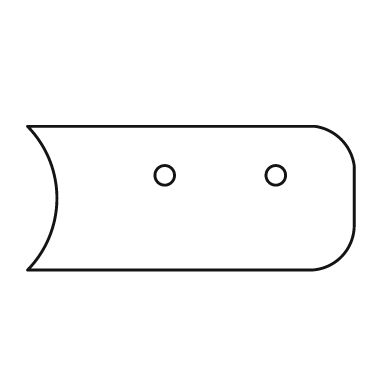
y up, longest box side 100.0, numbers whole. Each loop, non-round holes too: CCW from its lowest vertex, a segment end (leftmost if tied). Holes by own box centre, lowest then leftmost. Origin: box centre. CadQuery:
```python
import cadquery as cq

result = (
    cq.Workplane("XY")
    .moveTo(-50.0, -22.0)
    .lineTo(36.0, -22.0)
    .threePointArc((46.0, -18.0), (50.0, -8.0))
    .lineTo(50.0, 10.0)
    .threePointArc((46.0, 18.0), (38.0, 22.0))
    .lineTo(-50.0, 22.0)
    .threePointArc((-41.0, 0.0), (-50.0, -22.0))
    .close()
    .moveTo(-8.0, 7.0)
    .circle(3.0)
    .moveTo(26.0, 7.0)
    .circle(3.0)
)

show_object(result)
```